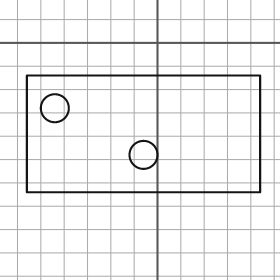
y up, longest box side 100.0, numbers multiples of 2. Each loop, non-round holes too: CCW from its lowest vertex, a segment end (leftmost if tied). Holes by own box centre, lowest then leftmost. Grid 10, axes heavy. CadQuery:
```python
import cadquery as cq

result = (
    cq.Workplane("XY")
    .moveTo(-56.0, -64.0)
    .lineTo(44.0, -64.0)
    .lineTo(44.0, -14.0)
    .lineTo(-56.0, -14.0)
    .close()
    .moveTo(-6.0, -48.0)
    .circle(6.0)
    .moveTo(-44.0, -28.0)
    .circle(6.0)
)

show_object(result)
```